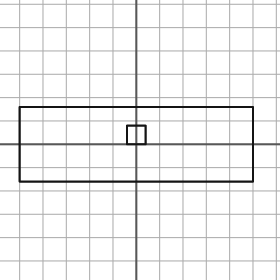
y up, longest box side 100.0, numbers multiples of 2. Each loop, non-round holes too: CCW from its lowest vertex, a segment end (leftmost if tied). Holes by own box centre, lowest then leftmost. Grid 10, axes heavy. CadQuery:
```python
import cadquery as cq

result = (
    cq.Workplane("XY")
    .moveTo(-50.0, -16.0)
    .lineTo(50.0, -16.0)
    .lineTo(50.0, 16.0)
    .lineTo(-50.0, 16.0)
    .close()
    .moveTo(-4.0, 0.0)
    .lineTo(4.0, 0.0)
    .lineTo(4.0, 8.0)
    .lineTo(-4.0, 8.0)
    .close()
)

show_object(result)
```